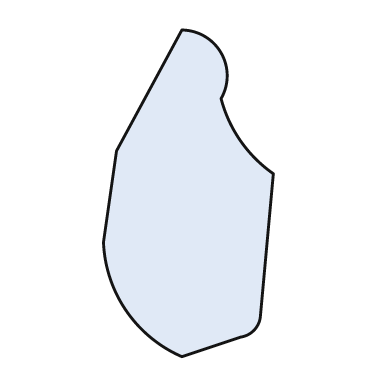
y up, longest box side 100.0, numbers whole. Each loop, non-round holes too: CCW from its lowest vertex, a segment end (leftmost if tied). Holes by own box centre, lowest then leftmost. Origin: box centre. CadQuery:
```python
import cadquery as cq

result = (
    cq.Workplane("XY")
    .moveTo(-2.0, -50.0)
    .lineTo(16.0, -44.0)
    .threePointArc((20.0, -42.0), (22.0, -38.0))
    .lineTo(26.0, 6.0)
    .threePointArc((16.0, 16.0), (10.0, 29.0))
    .threePointArc((10.0, 43.0), (-2.0, 50.0))
    .lineTo(-22.0, 13.0)
    .lineTo(-26.0, -15.0)
    .threePointArc((-19.0, -36.0), (-2.0, -50.0))
    .close()
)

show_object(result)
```